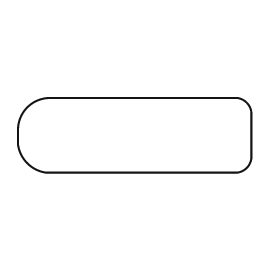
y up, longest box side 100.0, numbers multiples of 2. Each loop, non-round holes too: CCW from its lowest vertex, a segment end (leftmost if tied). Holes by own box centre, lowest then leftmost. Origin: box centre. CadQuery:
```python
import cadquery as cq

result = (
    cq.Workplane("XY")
    .moveTo(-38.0, -16.0)
    .lineTo(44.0, -16.0)
    .threePointArc((48.0, -14.0), (50.0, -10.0))
    .lineTo(50.0, 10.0)
    .threePointArc((48.0, 14.0), (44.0, 16.0))
    .lineTo(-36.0, 16.0)
    .threePointArc((-46.0, 12.0), (-50.0, 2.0))
    .lineTo(-50.0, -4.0)
    .threePointArc((-46.0, -12.0), (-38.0, -16.0))
    .close()
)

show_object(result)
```